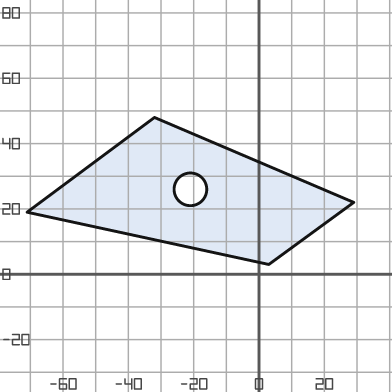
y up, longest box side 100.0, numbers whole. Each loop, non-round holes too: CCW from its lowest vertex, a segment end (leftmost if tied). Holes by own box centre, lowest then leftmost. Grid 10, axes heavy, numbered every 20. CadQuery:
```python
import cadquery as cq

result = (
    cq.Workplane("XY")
    .moveTo(3.0, 3.0)
    .lineTo(29.0, 22.0)
    .lineTo(-32.0, 48.0)
    .lineTo(-71.0, 19.0)
    .close()
    .moveTo(-21.0, 26.0)
    .circle(5.0)
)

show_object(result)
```